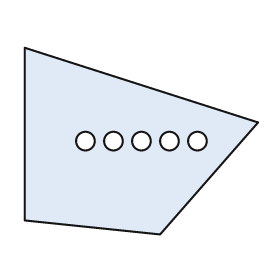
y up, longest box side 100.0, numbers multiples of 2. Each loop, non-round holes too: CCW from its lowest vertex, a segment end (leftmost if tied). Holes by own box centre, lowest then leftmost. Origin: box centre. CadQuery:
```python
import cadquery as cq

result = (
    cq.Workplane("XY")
    .moveTo(8.0, -40.0)
    .lineTo(50.0, 8.0)
    .lineTo(-50.0, 40.0)
    .lineTo(-50.0, -34.0)
    .close()
    .moveTo(-24.0, 0.0)
    .circle(4.0)
    .moveTo(-12.0, 0.0)
    .circle(4.0)
    .moveTo(0.0, 0.0)
    .circle(4.0)
    .moveTo(12.0, 0.0)
    .circle(4.0)
    .moveTo(24.0, 0.0)
    .circle(4.0)
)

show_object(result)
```